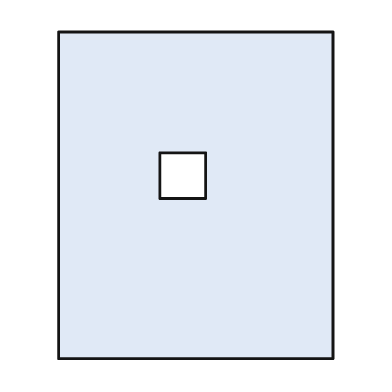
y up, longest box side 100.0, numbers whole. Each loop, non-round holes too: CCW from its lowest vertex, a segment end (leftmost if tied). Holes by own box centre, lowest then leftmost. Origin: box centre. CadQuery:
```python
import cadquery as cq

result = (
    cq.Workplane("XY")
    .moveTo(-42.0, -50.0)
    .lineTo(42.0, -50.0)
    .lineTo(42.0, 50.0)
    .lineTo(-42.0, 50.0)
    .close()
    .moveTo(-11.0, -1.0)
    .lineTo(3.0, -1.0)
    .lineTo(3.0, 13.0)
    .lineTo(-11.0, 13.0)
    .close()
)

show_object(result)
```